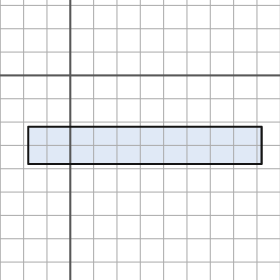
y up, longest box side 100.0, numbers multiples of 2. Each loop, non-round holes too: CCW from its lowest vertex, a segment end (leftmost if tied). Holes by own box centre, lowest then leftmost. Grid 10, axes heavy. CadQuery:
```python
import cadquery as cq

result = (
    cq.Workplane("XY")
    .moveTo(-18.0, -38.0)
    .lineTo(82.0, -38.0)
    .lineTo(82.0, -22.0)
    .lineTo(-18.0, -22.0)
    .close()
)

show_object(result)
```